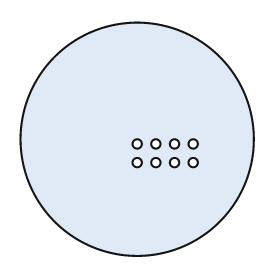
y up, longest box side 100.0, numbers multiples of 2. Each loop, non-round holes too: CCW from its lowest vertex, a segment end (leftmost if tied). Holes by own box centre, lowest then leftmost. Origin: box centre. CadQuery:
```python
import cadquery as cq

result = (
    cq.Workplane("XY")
    .moveTo(0.0, 0.0)
    .circle(50.0)
    .moveTo(0.0, -10.0)
    .circle(2.0)
    .moveTo(8.0, -10.0)
    .circle(2.0)
    .moveTo(16.0, -10.0)
    .circle(2.0)
    .moveTo(24.0, -10.0)
    .circle(2.0)
    .moveTo(0.0, -2.0)
    .circle(2.0)
    .moveTo(8.0, -2.0)
    .circle(2.0)
    .moveTo(16.0, -2.0)
    .circle(2.0)
    .moveTo(24.0, -2.0)
    .circle(2.0)
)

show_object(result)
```